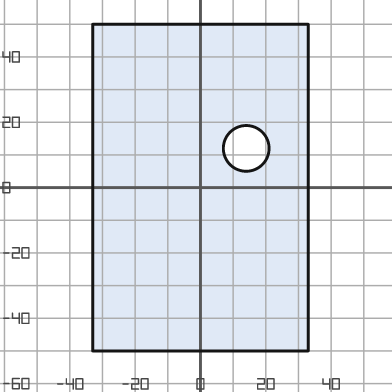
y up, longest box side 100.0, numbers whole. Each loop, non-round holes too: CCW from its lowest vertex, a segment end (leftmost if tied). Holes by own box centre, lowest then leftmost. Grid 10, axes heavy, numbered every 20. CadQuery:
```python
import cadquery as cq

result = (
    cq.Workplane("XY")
    .moveTo(-33.0, -50.0)
    .lineTo(33.0, -50.0)
    .lineTo(33.0, 50.0)
    .lineTo(-33.0, 50.0)
    .close()
    .moveTo(14.0, 12.0)
    .circle(7.0)
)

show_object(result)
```